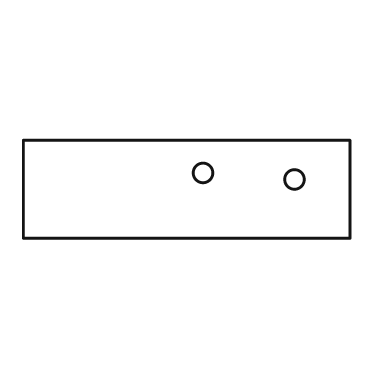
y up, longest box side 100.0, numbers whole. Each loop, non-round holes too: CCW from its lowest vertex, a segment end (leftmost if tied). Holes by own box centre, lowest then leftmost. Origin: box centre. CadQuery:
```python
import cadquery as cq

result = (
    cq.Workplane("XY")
    .moveTo(-50.0, -15.0)
    .lineTo(50.0, -15.0)
    .lineTo(50.0, 15.0)
    .lineTo(-50.0, 15.0)
    .close()
    .moveTo(33.0, 3.0)
    .circle(3.0)
    .moveTo(5.0, 5.0)
    .circle(3.0)
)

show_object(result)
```